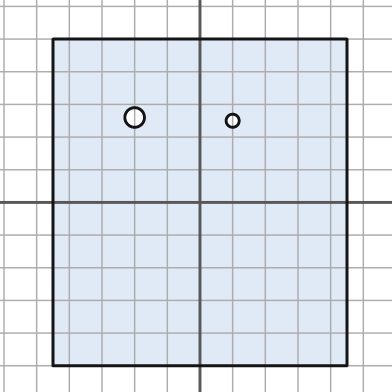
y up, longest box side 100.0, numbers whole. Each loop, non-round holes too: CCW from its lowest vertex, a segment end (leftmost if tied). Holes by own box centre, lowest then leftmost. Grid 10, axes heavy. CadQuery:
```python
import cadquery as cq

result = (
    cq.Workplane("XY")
    .moveTo(-45.0, -50.0)
    .lineTo(45.0, -50.0)
    .lineTo(45.0, 50.0)
    .lineTo(-45.0, 50.0)
    .close()
    .moveTo(10.0, 25.0)
    .circle(2.0)
    .moveTo(-20.0, 26.0)
    .circle(3.0)
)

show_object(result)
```